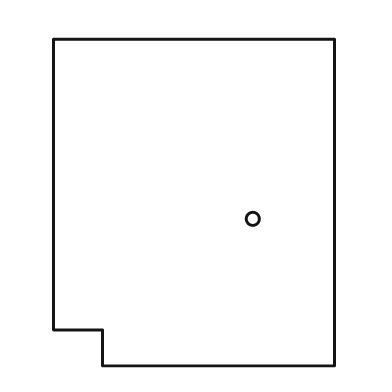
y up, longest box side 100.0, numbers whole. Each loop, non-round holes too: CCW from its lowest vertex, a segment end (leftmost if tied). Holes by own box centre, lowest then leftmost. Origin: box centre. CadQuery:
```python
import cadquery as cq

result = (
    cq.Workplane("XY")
    .moveTo(-28.0, -50.0)
    .lineTo(43.0, -50.0)
    .lineTo(43.0, 50.0)
    .lineTo(-43.0, 50.0)
    .lineTo(-43.0, -39.0)
    .lineTo(-28.0, -39.0)
    .close()
    .moveTo(18.0, -5.0)
    .circle(2.0)
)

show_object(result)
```